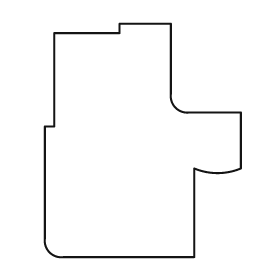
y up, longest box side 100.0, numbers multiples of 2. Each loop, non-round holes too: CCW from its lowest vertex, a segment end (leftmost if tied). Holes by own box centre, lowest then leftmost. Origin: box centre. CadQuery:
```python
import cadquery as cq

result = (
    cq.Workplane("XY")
    .moveTo(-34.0, -50.0)
    .lineTo(22.0, -50.0)
    .lineTo(22.0, -12.0)
    .threePointArc((32.0, -14.0), (42.0, -12.0))
    .lineTo(42.0, 12.0)
    .lineTo(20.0, 12.0)
    .threePointArc((14.0, 14.0), (12.0, 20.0))
    .lineTo(12.0, 50.0)
    .lineTo(-10.0, 50.0)
    .lineTo(-10.0, 46.0)
    .lineTo(-38.0, 46.0)
    .lineTo(-38.0, 6.0)
    .lineTo(-42.0, 6.0)
    .lineTo(-42.0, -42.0)
    .threePointArc((-40.0, -48.0), (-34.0, -50.0))
    .close()
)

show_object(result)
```